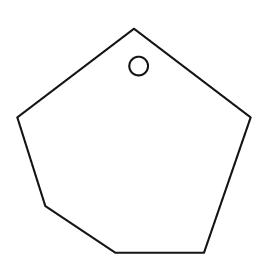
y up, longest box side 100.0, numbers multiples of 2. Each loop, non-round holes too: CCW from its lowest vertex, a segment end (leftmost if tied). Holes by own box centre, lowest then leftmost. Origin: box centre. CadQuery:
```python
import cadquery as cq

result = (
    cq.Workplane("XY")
    .moveTo(-8.0, -48.0)
    .lineTo(30.0, -48.0)
    .lineTo(50.0, 10.0)
    .lineTo(0.0, 48.0)
    .lineTo(-50.0, 10.0)
    .lineTo(-38.0, -28.0)
    .close()
    .moveTo(2.0, 32.0)
    .circle(4.0)
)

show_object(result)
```